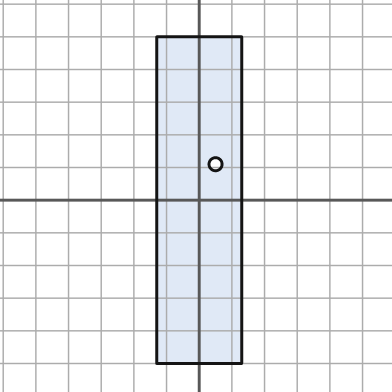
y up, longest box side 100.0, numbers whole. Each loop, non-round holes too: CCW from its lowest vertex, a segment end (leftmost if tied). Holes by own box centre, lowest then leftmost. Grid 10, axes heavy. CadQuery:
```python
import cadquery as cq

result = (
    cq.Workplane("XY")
    .moveTo(-13.0, -50.0)
    .lineTo(13.0, -50.0)
    .lineTo(13.0, 50.0)
    .lineTo(-13.0, 50.0)
    .close()
    .moveTo(5.0, 11.0)
    .circle(2.0)
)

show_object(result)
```